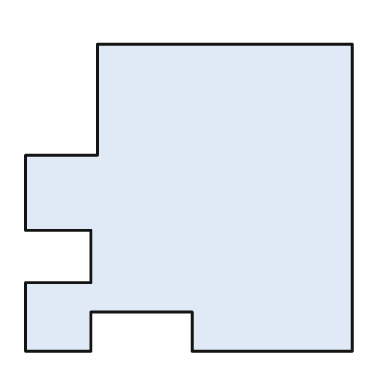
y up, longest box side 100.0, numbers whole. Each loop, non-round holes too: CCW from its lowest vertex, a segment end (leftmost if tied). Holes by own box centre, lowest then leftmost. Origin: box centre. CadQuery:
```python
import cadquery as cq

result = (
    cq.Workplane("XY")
    .moveTo(-50.0, -47.0)
    .lineTo(-30.0, -47.0)
    .lineTo(-30.0, -35.0)
    .lineTo(1.0, -35.0)
    .lineTo(1.0, -47.0)
    .lineTo(50.0, -47.0)
    .lineTo(50.0, 47.0)
    .lineTo(-28.0, 47.0)
    .lineTo(-28.0, 13.0)
    .lineTo(-50.0, 13.0)
    .lineTo(-50.0, -10.0)
    .lineTo(-30.0, -10.0)
    .lineTo(-30.0, -26.0)
    .lineTo(-50.0, -26.0)
    .close()
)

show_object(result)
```